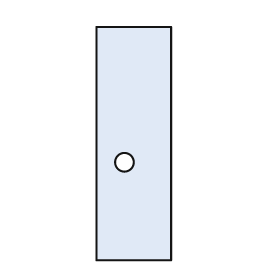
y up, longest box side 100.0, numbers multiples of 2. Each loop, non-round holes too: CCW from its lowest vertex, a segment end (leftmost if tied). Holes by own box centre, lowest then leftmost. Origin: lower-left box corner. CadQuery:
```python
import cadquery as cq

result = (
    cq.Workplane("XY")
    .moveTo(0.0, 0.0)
    .lineTo(32.0, 0.0)
    .lineTo(32.0, 100.0)
    .lineTo(0.0, 100.0)
    .close()
    .moveTo(12.0, 42.0)
    .circle(4.0)
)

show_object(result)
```